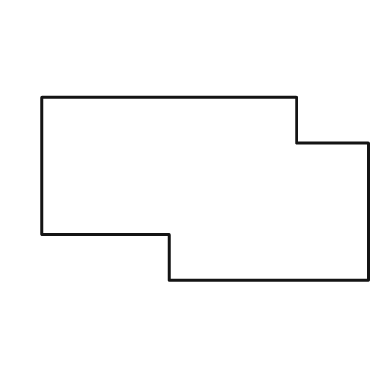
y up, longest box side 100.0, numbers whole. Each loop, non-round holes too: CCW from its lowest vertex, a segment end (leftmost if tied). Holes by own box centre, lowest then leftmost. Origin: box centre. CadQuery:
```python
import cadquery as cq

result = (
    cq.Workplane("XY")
    .moveTo(-11.0, -28.0)
    .lineTo(50.0, -28.0)
    .lineTo(50.0, 14.0)
    .lineTo(28.0, 14.0)
    .lineTo(28.0, 28.0)
    .lineTo(-50.0, 28.0)
    .lineTo(-50.0, -14.0)
    .lineTo(-11.0, -14.0)
    .close()
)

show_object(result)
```